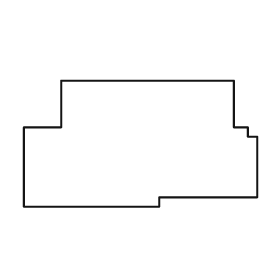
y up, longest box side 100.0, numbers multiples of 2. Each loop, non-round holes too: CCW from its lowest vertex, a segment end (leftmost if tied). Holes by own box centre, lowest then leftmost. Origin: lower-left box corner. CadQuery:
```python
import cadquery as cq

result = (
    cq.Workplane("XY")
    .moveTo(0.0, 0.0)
    .lineTo(58.0, 0.0)
    .lineTo(58.0, 4.0)
    .lineTo(100.0, 4.0)
    .lineTo(100.0, 30.0)
    .lineTo(96.0, 30.0)
    .lineTo(96.0, 34.0)
    .lineTo(90.0, 34.0)
    .lineTo(90.0, 54.0)
    .lineTo(16.0, 54.0)
    .lineTo(16.0, 34.0)
    .lineTo(0.0, 34.0)
    .close()
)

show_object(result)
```